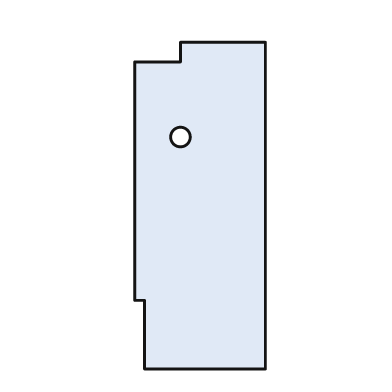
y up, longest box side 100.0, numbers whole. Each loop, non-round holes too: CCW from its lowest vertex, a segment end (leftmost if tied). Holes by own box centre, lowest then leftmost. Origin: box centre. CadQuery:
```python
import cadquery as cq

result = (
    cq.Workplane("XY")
    .moveTo(-17.0, -50.0)
    .lineTo(20.0, -50.0)
    .lineTo(20.0, 50.0)
    .lineTo(-6.0, 50.0)
    .lineTo(-6.0, 44.0)
    .lineTo(-20.0, 44.0)
    .lineTo(-20.0, -29.0)
    .lineTo(-17.0, -29.0)
    .close()
    .moveTo(-6.0, 21.0)
    .circle(3.0)
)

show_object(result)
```